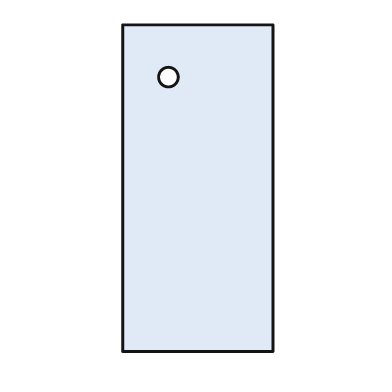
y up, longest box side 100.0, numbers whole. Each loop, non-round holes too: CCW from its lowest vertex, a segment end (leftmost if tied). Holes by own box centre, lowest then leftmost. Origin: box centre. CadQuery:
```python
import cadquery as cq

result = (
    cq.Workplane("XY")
    .moveTo(-23.0, -50.0)
    .lineTo(23.0, -50.0)
    .lineTo(23.0, 50.0)
    .lineTo(-23.0, 50.0)
    .close()
    .moveTo(-9.0, 34.0)
    .circle(3.0)
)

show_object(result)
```